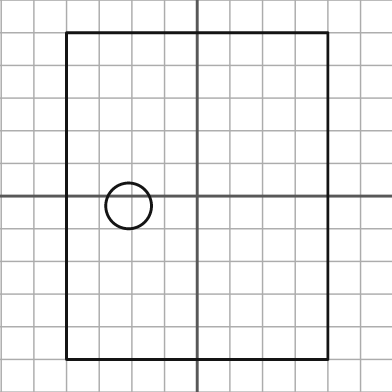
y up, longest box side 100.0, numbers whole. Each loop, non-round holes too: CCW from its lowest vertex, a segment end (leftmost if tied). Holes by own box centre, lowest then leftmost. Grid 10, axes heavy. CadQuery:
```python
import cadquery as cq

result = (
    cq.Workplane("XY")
    .moveTo(-40.0, -50.0)
    .lineTo(40.0, -50.0)
    .lineTo(40.0, 50.0)
    .lineTo(-40.0, 50.0)
    .close()
    .moveTo(-21.0, -3.0)
    .circle(7.0)
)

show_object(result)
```